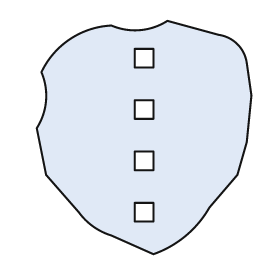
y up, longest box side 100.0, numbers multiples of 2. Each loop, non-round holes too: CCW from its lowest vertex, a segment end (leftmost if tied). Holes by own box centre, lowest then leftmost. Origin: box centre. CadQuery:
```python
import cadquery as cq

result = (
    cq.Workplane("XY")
    .moveTo(4.0, -50.0)
    .threePointArc((18.0, -42.0), (28.0, -30.0))
    .lineTo(40.0, -16.0)
    .lineTo(44.0, -2.0)
    .lineTo(46.0, 18.0)
    .lineTo(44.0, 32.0)
    .threePointArc((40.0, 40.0), (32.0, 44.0))
    .lineTo(10.0, 50.0)
    .threePointArc((-2.0, 46.0), (-14.0, 48.0))
    .threePointArc((-32.0, 42.0), (-44.0, 28.0))
    .threePointArc((-42.0, 16.0), (-46.0, 4.0))
    .lineTo(-42.0, -16.0)
    .lineTo(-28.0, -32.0)
    .threePointArc((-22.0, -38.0), (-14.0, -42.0))
    .close()
    .moveTo(-4.0, -36.0)
    .lineTo(4.0, -36.0)
    .lineTo(4.0, -28.0)
    .lineTo(-4.0, -28.0)
    .close()
    .moveTo(-4.0, -14.0)
    .lineTo(4.0, -14.0)
    .lineTo(4.0, -6.0)
    .lineTo(-4.0, -6.0)
    .close()
    .moveTo(-4.0, 8.0)
    .lineTo(4.0, 8.0)
    .lineTo(4.0, 16.0)
    .lineTo(-4.0, 16.0)
    .close()
    .moveTo(-4.0, 30.0)
    .lineTo(4.0, 30.0)
    .lineTo(4.0, 38.0)
    .lineTo(-4.0, 38.0)
    .close()
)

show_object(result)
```